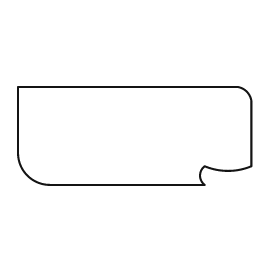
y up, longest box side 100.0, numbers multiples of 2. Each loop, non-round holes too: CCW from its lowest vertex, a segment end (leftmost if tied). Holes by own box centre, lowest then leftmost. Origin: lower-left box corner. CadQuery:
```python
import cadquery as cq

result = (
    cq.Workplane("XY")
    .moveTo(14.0, 0.0)
    .lineTo(80.0, 0.0)
    .threePointArc((78.0, 4.0), (80.0, 8.0))
    .threePointArc((90.0, 6.0), (100.0, 8.0))
    .lineTo(100.0, 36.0)
    .threePointArc((98.0, 40.0), (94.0, 42.0))
    .lineTo(0.0, 42.0)
    .lineTo(0.0, 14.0)
    .threePointArc((4.0, 4.0), (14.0, 0.0))
    .close()
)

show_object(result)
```